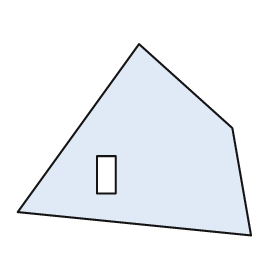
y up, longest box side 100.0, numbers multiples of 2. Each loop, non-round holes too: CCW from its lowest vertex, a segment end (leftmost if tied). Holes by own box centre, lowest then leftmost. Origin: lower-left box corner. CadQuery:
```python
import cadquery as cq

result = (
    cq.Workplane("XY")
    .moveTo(100.0, 0.0)
    .lineTo(92.0, 46.0)
    .lineTo(52.0, 82.0)
    .lineTo(0.0, 10.0)
    .close()
    .moveTo(34.0, 18.0)
    .lineTo(42.0, 18.0)
    .lineTo(42.0, 34.0)
    .lineTo(34.0, 34.0)
    .close()
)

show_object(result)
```